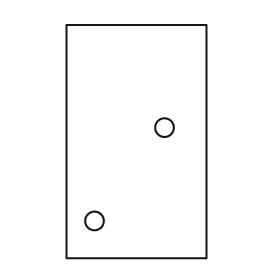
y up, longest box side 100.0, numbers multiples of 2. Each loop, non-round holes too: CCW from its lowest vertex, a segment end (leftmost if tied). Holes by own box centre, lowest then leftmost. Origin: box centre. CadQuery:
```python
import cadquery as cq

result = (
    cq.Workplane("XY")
    .moveTo(-30.0, -50.0)
    .lineTo(30.0, -50.0)
    .lineTo(30.0, 50.0)
    .lineTo(-30.0, 50.0)
    .close()
    .moveTo(-18.0, -34.0)
    .circle(4.0)
    .moveTo(12.0, 6.0)
    .circle(4.0)
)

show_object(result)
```